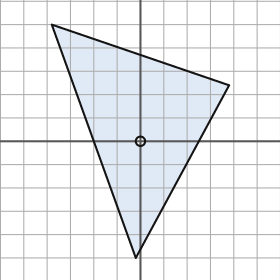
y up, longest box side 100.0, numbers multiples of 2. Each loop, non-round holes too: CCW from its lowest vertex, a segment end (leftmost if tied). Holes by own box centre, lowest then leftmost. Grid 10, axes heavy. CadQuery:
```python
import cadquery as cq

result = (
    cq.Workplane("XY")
    .moveTo(-2.0, -50.0)
    .lineTo(38.0, 24.0)
    .lineTo(-38.0, 50.0)
    .close()
    .moveTo(0.0, 0.0)
    .circle(2.0)
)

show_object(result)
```